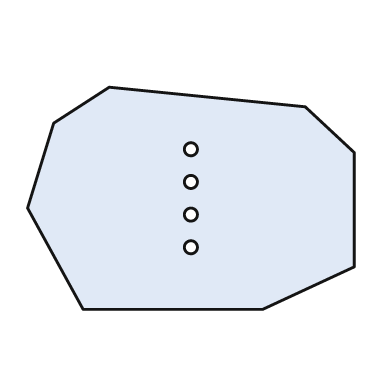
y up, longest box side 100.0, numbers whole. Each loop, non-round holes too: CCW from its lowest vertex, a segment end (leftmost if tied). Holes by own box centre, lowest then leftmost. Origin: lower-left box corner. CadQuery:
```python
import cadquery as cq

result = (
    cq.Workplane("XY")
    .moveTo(17.0, 0.0)
    .lineTo(72.0, 0.0)
    .lineTo(100.0, 13.0)
    .lineTo(100.0, 48.0)
    .lineTo(85.0, 62.0)
    .lineTo(25.0, 68.0)
    .lineTo(8.0, 57.0)
    .lineTo(0.0, 31.0)
    .close()
    .moveTo(50.0, 19.0)
    .circle(2.0)
    .moveTo(50.0, 29.0)
    .circle(2.0)
    .moveTo(50.0, 39.0)
    .circle(2.0)
    .moveTo(50.0, 49.0)
    .circle(2.0)
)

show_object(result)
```